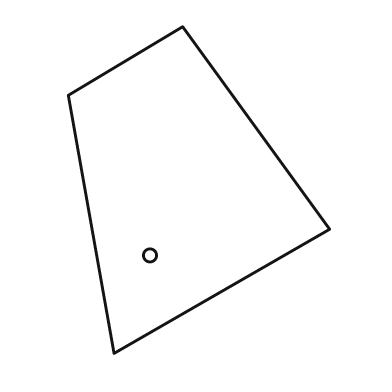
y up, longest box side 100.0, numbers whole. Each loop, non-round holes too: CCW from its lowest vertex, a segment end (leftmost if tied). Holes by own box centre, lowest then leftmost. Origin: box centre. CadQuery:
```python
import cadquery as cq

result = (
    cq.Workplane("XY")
    .moveTo(-26.0, -50.0)
    .lineTo(40.0, -12.0)
    .lineTo(-5.0, 50.0)
    .lineTo(-40.0, 29.0)
    .close()
    .moveTo(-15.0, -20.0)
    .circle(2.0)
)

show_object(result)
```